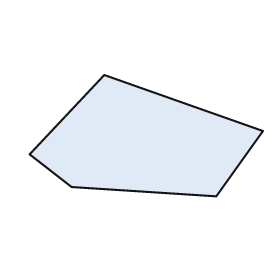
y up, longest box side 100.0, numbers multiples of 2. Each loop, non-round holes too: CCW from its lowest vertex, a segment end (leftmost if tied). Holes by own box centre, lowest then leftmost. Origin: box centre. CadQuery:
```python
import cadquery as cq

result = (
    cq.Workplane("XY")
    .moveTo(30.0, -26.0)
    .lineTo(50.0, 2.0)
    .lineTo(-18.0, 26.0)
    .lineTo(-50.0, -8.0)
    .lineTo(-32.0, -22.0)
    .close()
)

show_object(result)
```